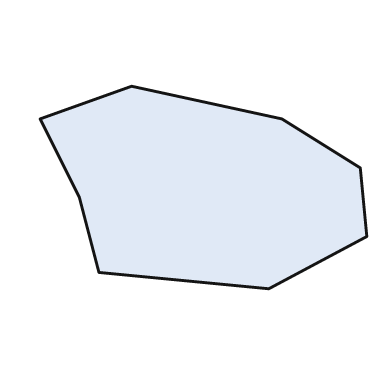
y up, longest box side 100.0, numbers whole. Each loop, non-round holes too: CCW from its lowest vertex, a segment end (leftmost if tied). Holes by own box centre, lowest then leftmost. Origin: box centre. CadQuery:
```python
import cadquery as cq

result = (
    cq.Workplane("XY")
    .moveTo(20.0, -31.0)
    .lineTo(50.0, -15.0)
    .lineTo(48.0, 6.0)
    .lineTo(24.0, 21.0)
    .lineTo(-22.0, 31.0)
    .lineTo(-50.0, 21.0)
    .lineTo(-38.0, -3.0)
    .lineTo(-32.0, -26.0)
    .close()
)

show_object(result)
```